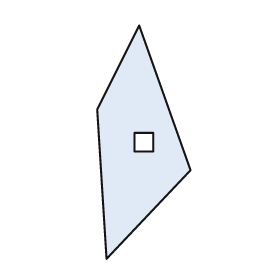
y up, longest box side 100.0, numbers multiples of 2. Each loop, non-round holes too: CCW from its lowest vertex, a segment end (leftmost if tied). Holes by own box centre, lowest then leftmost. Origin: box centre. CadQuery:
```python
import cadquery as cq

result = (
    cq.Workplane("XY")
    .moveTo(-16.0, -50.0)
    .lineTo(20.0, -12.0)
    .lineTo(-2.0, 50.0)
    .lineTo(-20.0, 14.0)
    .close()
    .moveTo(-4.0, -4.0)
    .lineTo(4.0, -4.0)
    .lineTo(4.0, 4.0)
    .lineTo(-4.0, 4.0)
    .close()
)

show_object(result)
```